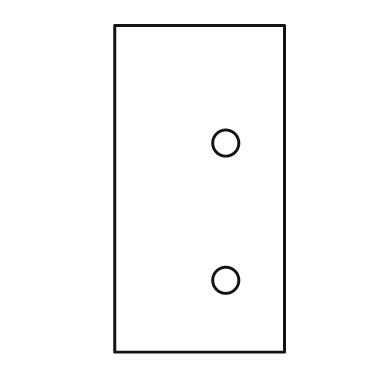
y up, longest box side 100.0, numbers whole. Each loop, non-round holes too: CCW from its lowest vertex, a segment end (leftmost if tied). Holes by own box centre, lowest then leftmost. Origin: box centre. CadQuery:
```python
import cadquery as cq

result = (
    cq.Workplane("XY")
    .moveTo(-26.0, -50.0)
    .lineTo(26.0, -50.0)
    .lineTo(26.0, 50.0)
    .lineTo(-26.0, 50.0)
    .close()
    .moveTo(8.0, -28.0)
    .circle(4.0)
    .moveTo(8.0, 14.0)
    .circle(4.0)
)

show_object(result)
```